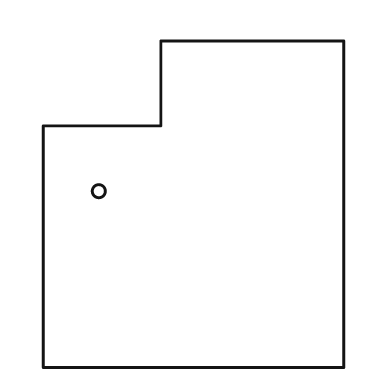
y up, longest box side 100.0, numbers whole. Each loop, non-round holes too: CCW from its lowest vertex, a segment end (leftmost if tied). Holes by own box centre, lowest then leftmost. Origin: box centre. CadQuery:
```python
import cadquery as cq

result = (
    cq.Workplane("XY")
    .moveTo(-46.0, -50.0)
    .lineTo(46.0, -50.0)
    .lineTo(46.0, 50.0)
    .lineTo(-10.0, 50.0)
    .lineTo(-10.0, 24.0)
    .lineTo(-46.0, 24.0)
    .close()
    .moveTo(-29.0, 4.0)
    .circle(2.0)
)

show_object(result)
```